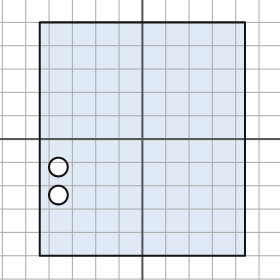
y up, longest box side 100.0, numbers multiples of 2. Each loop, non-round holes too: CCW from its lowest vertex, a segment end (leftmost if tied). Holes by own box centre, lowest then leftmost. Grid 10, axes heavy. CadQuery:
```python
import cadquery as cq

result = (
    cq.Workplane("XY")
    .moveTo(-44.0, -50.0)
    .lineTo(44.0, -50.0)
    .lineTo(44.0, 50.0)
    .lineTo(-44.0, 50.0)
    .close()
    .moveTo(-36.0, -24.0)
    .circle(4.0)
    .moveTo(-36.0, -12.0)
    .circle(4.0)
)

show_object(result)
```